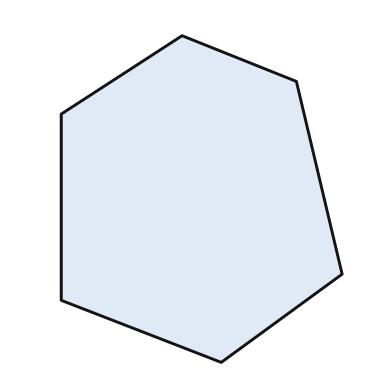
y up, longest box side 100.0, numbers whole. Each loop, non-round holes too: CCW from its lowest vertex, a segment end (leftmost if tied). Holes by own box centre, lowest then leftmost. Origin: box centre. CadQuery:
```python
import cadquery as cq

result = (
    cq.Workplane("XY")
    .moveTo(6.0, -50.0)
    .lineTo(43.0, -23.0)
    .lineTo(29.0, 36.0)
    .lineTo(-6.0, 50.0)
    .lineTo(-43.0, 26.0)
    .lineTo(-43.0, -31.0)
    .close()
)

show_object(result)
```